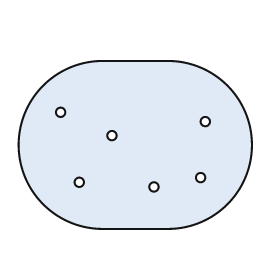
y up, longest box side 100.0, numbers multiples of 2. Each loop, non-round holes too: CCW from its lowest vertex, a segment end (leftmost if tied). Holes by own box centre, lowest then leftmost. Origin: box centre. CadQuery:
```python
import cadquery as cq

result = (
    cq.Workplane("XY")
    .moveTo(-14.0, -36.0)
    .lineTo(14.0, -36.0)
    .threePointArc((50.0, 0.0), (14.0, 36.0))
    .lineTo(-14.0, 36.0)
    .threePointArc((-50.0, 0.0), (-14.0, -36.0))
    .close()
    .moveTo(8.0, -18.0)
    .circle(2.0)
    .moveTo(-24.0, -16.0)
    .circle(2.0)
    .moveTo(28.0, -14.0)
    .circle(2.0)
    .moveTo(-10.0, 4.0)
    .circle(2.0)
    .moveTo(30.0, 10.0)
    .circle(2.0)
    .moveTo(-32.0, 14.0)
    .circle(2.0)
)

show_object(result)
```